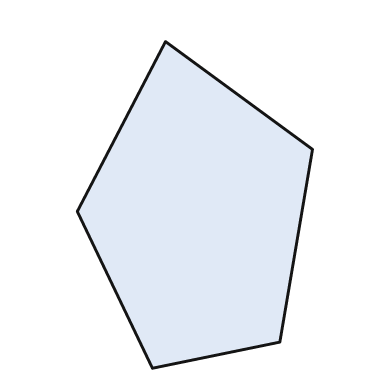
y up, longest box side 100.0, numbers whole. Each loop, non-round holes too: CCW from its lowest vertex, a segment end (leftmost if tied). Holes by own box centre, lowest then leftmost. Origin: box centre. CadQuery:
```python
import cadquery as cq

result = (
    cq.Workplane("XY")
    .moveTo(-13.0, -50.0)
    .lineTo(26.0, -42.0)
    .lineTo(36.0, 17.0)
    .lineTo(-9.0, 50.0)
    .lineTo(-36.0, -2.0)
    .close()
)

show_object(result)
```